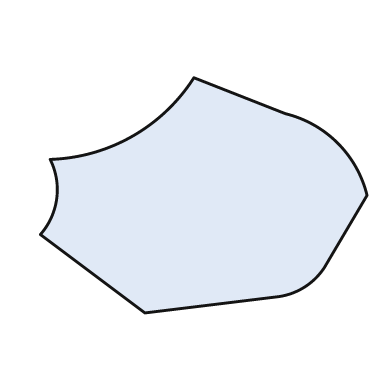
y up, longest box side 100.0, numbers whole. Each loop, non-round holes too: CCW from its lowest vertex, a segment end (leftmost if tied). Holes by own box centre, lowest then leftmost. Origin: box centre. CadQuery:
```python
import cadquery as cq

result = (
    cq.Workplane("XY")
    .moveTo(-18.0, -36.0)
    .lineTo(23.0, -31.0)
    .threePointArc((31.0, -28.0), (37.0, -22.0))
    .lineTo(50.0, 0.0)
    .threePointArc((41.0, 16.0), (25.0, 25.0))
    .lineTo(-3.0, 36.0)
    .threePointArc((-22.0, 18.0), (-47.0, 11.0))
    .threePointArc((-45.0, -1.0), (-50.0, -12.0))
    .close()
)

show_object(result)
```